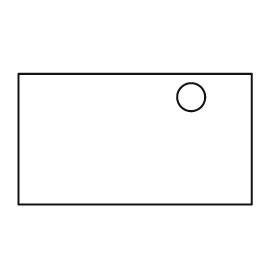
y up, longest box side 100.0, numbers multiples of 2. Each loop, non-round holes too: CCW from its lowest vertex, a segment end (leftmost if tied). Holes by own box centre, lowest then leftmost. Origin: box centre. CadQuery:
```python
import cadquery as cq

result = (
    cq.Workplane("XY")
    .moveTo(-50.0, -28.0)
    .lineTo(50.0, -28.0)
    .lineTo(50.0, 28.0)
    .lineTo(-50.0, 28.0)
    .close()
    .moveTo(24.0, 18.0)
    .circle(6.0)
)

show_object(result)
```